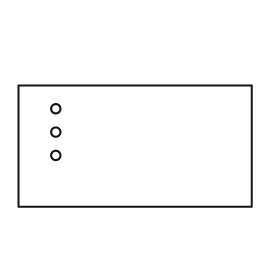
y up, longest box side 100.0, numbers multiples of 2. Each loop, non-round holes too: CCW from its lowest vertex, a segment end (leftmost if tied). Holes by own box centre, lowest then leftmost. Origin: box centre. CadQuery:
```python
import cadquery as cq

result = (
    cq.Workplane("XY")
    .moveTo(-50.0, -26.0)
    .lineTo(50.0, -26.0)
    .lineTo(50.0, 26.0)
    .lineTo(-50.0, 26.0)
    .close()
    .moveTo(-34.0, -4.0)
    .circle(2.0)
    .moveTo(-34.0, 6.0)
    .circle(2.0)
    .moveTo(-34.0, 16.0)
    .circle(2.0)
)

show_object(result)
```